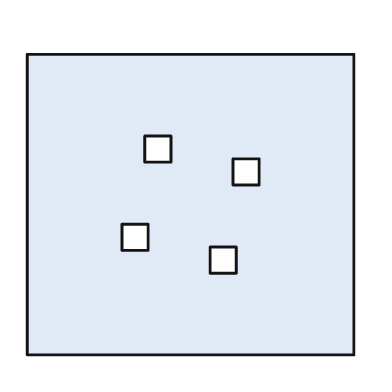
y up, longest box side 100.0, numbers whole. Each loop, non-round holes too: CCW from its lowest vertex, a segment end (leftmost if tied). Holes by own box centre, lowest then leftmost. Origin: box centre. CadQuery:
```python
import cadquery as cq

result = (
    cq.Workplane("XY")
    .moveTo(-50.0, -46.0)
    .lineTo(50.0, -46.0)
    .lineTo(50.0, 46.0)
    .lineTo(-50.0, 46.0)
    .close()
    .moveTo(6.0, -21.0)
    .lineTo(14.0, -21.0)
    .lineTo(14.0, -13.0)
    .lineTo(6.0, -13.0)
    .close()
    .moveTo(-21.0, -14.0)
    .lineTo(-13.0, -14.0)
    .lineTo(-13.0, -6.0)
    .lineTo(-21.0, -6.0)
    .close()
    .moveTo(13.0, 6.0)
    .lineTo(21.0, 6.0)
    .lineTo(21.0, 14.0)
    .lineTo(13.0, 14.0)
    .close()
    .moveTo(-14.0, 13.0)
    .lineTo(-6.0, 13.0)
    .lineTo(-6.0, 21.0)
    .lineTo(-14.0, 21.0)
    .close()
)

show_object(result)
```